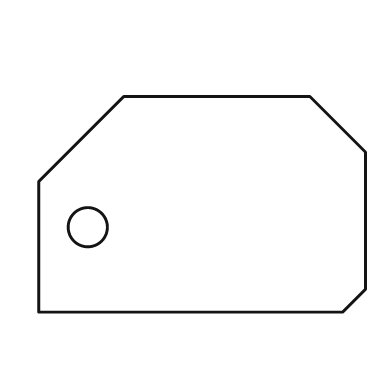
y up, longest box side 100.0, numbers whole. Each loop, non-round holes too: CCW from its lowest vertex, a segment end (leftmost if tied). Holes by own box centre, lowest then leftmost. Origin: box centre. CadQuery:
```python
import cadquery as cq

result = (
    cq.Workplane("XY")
    .moveTo(-50.0, -33.0)
    .lineTo(43.0, -33.0)
    .lineTo(50.0, -26.0)
    .lineTo(50.0, 16.0)
    .lineTo(33.0, 33.0)
    .lineTo(-24.0, 33.0)
    .lineTo(-50.0, 7.0)
    .close()
    .moveTo(-35.0, -7.0)
    .circle(6.0)
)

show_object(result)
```